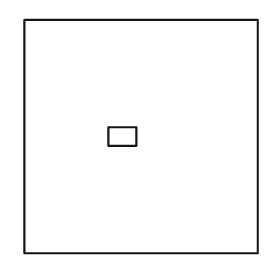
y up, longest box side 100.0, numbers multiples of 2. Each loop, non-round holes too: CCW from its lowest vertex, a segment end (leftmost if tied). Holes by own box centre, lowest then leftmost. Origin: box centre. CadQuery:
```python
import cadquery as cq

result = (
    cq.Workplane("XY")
    .moveTo(-50.0, -50.0)
    .lineTo(50.0, -50.0)
    .lineTo(50.0, 50.0)
    .lineTo(-50.0, 50.0)
    .close()
    .moveTo(-14.0, -4.0)
    .lineTo(-2.0, -4.0)
    .lineTo(-2.0, 4.0)
    .lineTo(-14.0, 4.0)
    .close()
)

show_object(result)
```